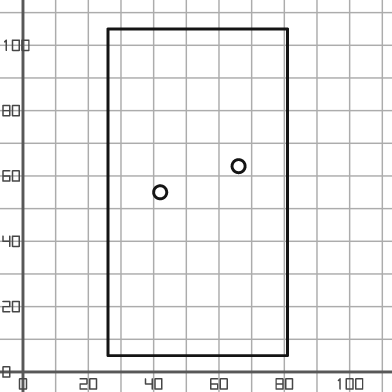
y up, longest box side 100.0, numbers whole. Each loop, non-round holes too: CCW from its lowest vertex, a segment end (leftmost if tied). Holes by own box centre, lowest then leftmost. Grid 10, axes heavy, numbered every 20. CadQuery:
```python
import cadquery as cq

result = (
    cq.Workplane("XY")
    .moveTo(26.0, 5.0)
    .lineTo(81.0, 5.0)
    .lineTo(81.0, 105.0)
    .lineTo(26.0, 105.0)
    .close()
    .moveTo(42.0, 55.0)
    .circle(2.0)
    .moveTo(66.0, 63.0)
    .circle(2.0)
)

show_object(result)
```